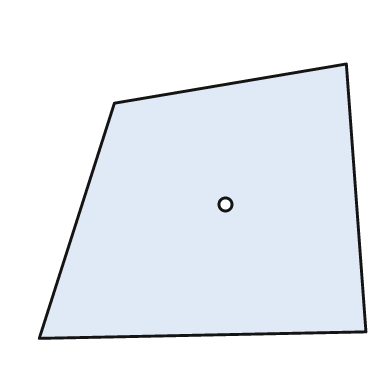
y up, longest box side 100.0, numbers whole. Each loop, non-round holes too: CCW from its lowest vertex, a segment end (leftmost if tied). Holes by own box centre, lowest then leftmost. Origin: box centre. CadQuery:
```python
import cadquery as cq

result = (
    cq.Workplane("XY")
    .moveTo(-50.0, -42.0)
    .lineTo(50.0, -40.0)
    .lineTo(44.0, 42.0)
    .lineTo(-27.0, 30.0)
    .close()
    .moveTo(7.0, -1.0)
    .circle(2.0)
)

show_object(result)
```